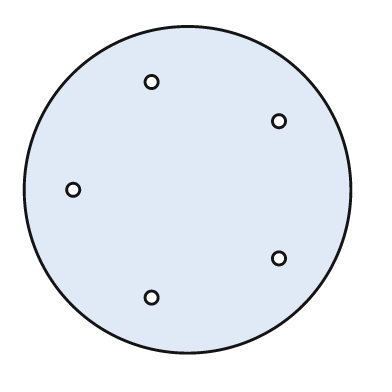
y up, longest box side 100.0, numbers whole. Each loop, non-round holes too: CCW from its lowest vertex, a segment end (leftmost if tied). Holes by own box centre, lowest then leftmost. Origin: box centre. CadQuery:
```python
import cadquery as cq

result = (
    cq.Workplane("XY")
    .moveTo(0.0, 0.0)
    .circle(50.0)
    .moveTo(-11.0, -33.0)
    .circle(2.0)
    .moveTo(28.0, -21.0)
    .circle(2.0)
    .moveTo(-35.0, 0.0)
    .circle(2.0)
    .moveTo(28.0, 21.0)
    .circle(2.0)
    .moveTo(-11.0, 33.0)
    .circle(2.0)
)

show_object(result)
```